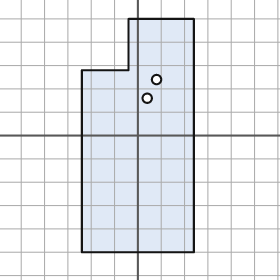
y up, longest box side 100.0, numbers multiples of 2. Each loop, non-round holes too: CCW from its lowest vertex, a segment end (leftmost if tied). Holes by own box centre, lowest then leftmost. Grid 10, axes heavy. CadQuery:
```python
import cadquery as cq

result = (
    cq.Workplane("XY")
    .moveTo(-24.0, -50.0)
    .lineTo(24.0, -50.0)
    .lineTo(24.0, 50.0)
    .lineTo(-4.0, 50.0)
    .lineTo(-4.0, 28.0)
    .lineTo(-24.0, 28.0)
    .close()
    .moveTo(4.0, 16.0)
    .circle(2.0)
    .moveTo(8.0, 24.0)
    .circle(2.0)
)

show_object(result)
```